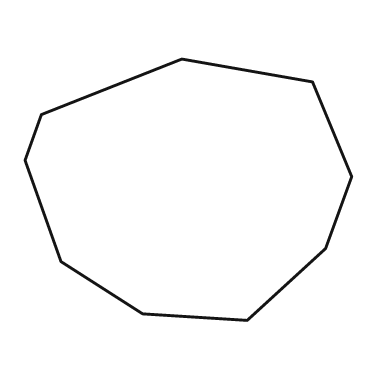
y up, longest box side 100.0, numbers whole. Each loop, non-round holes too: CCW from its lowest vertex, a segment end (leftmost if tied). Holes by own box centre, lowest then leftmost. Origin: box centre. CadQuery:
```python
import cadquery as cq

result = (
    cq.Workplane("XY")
    .moveTo(18.0, -40.0)
    .lineTo(42.0, -18.0)
    .lineTo(50.0, 4.0)
    .lineTo(38.0, 33.0)
    .lineTo(-2.0, 40.0)
    .lineTo(-45.0, 23.0)
    .lineTo(-50.0, 9.0)
    .lineTo(-39.0, -22.0)
    .lineTo(-14.0, -38.0)
    .close()
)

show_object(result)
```